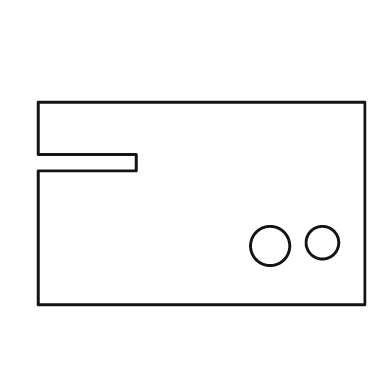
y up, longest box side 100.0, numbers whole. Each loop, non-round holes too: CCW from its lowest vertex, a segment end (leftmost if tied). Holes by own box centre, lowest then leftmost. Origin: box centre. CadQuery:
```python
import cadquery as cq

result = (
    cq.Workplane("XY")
    .moveTo(-50.0, -31.0)
    .lineTo(50.0, -31.0)
    .lineTo(50.0, 31.0)
    .lineTo(-50.0, 31.0)
    .lineTo(-50.0, 15.0)
    .lineTo(-20.0, 15.0)
    .lineTo(-20.0, 10.0)
    .lineTo(-50.0, 10.0)
    .close()
    .moveTo(21.0, -13.0)
    .circle(6.0)
    .moveTo(37.0, -12.0)
    .circle(5.0)
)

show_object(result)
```